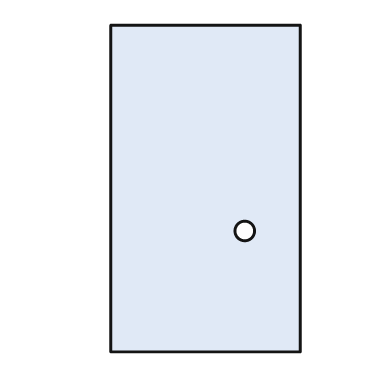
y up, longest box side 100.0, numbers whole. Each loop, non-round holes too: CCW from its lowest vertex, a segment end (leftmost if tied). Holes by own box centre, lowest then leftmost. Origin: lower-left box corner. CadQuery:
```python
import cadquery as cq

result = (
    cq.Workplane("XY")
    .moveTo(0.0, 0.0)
    .lineTo(58.0, 0.0)
    .lineTo(58.0, 100.0)
    .lineTo(0.0, 100.0)
    .close()
    .moveTo(41.0, 37.0)
    .circle(3.0)
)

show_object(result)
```